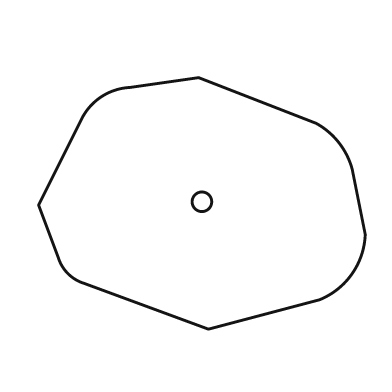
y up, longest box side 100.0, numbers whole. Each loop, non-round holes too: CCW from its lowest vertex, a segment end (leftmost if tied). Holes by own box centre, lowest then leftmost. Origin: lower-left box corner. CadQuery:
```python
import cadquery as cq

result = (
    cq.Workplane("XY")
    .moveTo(52.0, 0.0)
    .lineTo(86.0, 9.0)
    .threePointArc((96.0, 17.0), (100.0, 29.0))
    .lineTo(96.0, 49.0)
    .threePointArc((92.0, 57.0), (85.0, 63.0))
    .lineTo(49.0, 77.0)
    .lineTo(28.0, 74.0)
    .threePointArc((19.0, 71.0), (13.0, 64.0))
    .lineTo(0.0, 38.0)
    .lineTo(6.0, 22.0)
    .threePointArc((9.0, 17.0), (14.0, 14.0))
    .close()
    .moveTo(50.0, 39.0)
    .circle(3.0)
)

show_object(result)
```